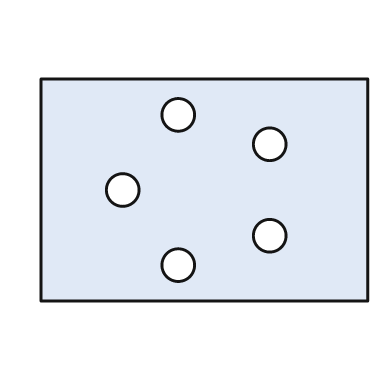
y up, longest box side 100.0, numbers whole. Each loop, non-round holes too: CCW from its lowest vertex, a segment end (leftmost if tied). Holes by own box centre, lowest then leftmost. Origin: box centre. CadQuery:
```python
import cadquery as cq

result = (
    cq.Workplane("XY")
    .moveTo(-50.0, -34.0)
    .lineTo(50.0, -34.0)
    .lineTo(50.0, 34.0)
    .lineTo(-50.0, 34.0)
    .close()
    .moveTo(-8.0, -23.0)
    .circle(5.0)
    .moveTo(20.0, -14.0)
    .circle(5.0)
    .moveTo(-25.0, 0.0)
    .circle(5.0)
    .moveTo(20.0, 14.0)
    .circle(5.0)
    .moveTo(-8.0, 23.0)
    .circle(5.0)
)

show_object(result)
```